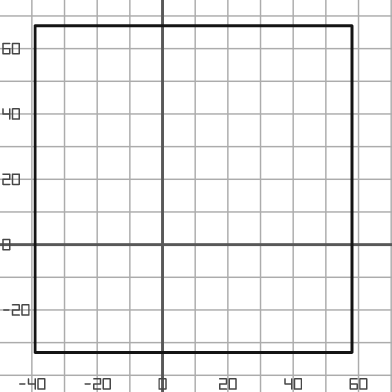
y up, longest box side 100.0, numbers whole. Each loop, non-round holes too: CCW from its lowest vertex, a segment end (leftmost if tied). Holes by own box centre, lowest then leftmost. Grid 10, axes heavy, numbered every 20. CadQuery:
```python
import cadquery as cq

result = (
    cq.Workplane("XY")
    .moveTo(-39.0, -33.0)
    .lineTo(58.0, -33.0)
    .lineTo(58.0, 67.0)
    .lineTo(-39.0, 67.0)
    .close()
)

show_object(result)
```